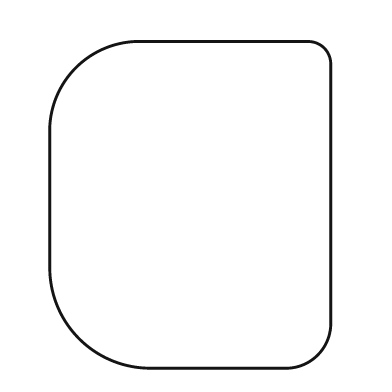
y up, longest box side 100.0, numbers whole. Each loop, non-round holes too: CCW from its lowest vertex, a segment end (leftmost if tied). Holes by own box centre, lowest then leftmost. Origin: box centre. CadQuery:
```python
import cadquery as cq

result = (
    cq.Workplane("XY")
    .moveTo(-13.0, -50.0)
    .lineTo(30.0, -50.0)
    .threePointArc((39.0, -46.0), (43.0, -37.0))
    .lineTo(43.0, 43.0)
    .threePointArc((41.0, 48.0), (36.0, 50.0))
    .lineTo(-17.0, 50.0)
    .threePointArc((-35.0, 42.0), (-43.0, 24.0))
    .lineTo(-43.0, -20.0)
    .threePointArc((-34.0, -41.0), (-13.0, -50.0))
    .close()
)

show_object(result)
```